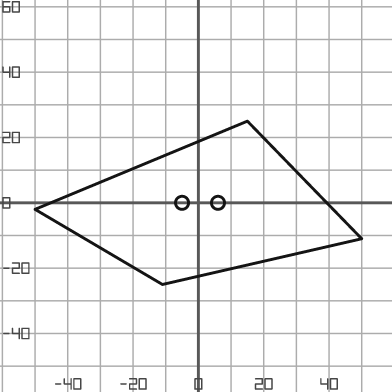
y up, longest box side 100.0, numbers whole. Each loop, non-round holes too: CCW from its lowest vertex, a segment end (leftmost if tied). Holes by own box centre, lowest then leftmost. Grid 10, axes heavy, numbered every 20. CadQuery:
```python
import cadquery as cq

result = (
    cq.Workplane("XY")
    .moveTo(-11.0, -25.0)
    .lineTo(50.0, -11.0)
    .lineTo(15.0, 25.0)
    .lineTo(-50.0, -2.0)
    .close()
    .moveTo(-5.0, 0.0)
    .circle(2.0)
    .moveTo(6.0, 0.0)
    .circle(2.0)
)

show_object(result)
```